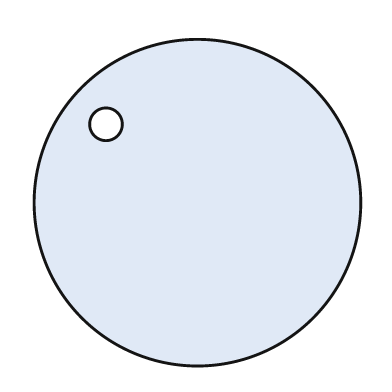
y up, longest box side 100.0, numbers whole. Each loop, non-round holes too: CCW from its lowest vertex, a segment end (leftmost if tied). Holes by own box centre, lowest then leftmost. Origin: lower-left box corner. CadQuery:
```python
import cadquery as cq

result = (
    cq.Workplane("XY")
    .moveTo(50.0, 50.0)
    .circle(50.0)
    .moveTo(22.0, 74.0)
    .circle(5.0)
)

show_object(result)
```